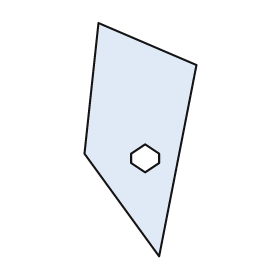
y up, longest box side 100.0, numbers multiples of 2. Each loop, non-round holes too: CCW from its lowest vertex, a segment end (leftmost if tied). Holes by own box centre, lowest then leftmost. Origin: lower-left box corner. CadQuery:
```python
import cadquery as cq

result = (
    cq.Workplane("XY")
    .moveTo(32.0, 0.0)
    .lineTo(48.0, 82.0)
    .lineTo(6.0, 100.0)
    .lineTo(0.0, 44.0)
    .close()
    .moveTo(26.0, 36.0)
    .lineTo(32.0, 40.0)
    .lineTo(32.0, 44.0)
    .lineTo(26.0, 48.0)
    .lineTo(20.0, 44.0)
    .lineTo(20.0, 40.0)
    .close()
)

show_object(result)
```